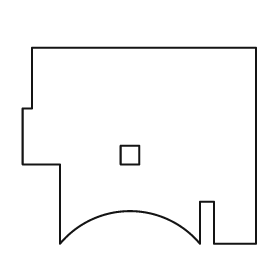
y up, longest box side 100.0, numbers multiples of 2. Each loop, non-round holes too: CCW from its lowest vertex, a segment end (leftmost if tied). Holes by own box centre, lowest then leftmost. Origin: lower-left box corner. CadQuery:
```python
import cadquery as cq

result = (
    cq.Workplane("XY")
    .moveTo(16.0, 0.0)
    .threePointArc((46.0, 14.0), (76.0, 0.0))
    .lineTo(76.0, 18.0)
    .lineTo(82.0, 18.0)
    .lineTo(82.0, 0.0)
    .lineTo(100.0, 0.0)
    .lineTo(100.0, 84.0)
    .lineTo(4.0, 84.0)
    .lineTo(4.0, 58.0)
    .lineTo(0.0, 58.0)
    .lineTo(0.0, 34.0)
    .lineTo(16.0, 34.0)
    .close()
    .moveTo(42.0, 34.0)
    .lineTo(50.0, 34.0)
    .lineTo(50.0, 42.0)
    .lineTo(42.0, 42.0)
    .close()
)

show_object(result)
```